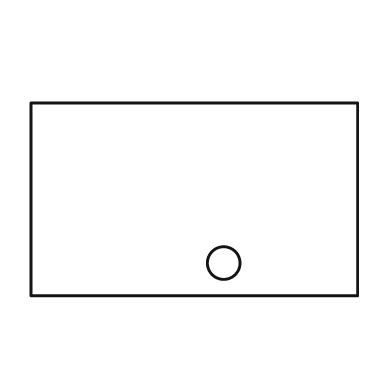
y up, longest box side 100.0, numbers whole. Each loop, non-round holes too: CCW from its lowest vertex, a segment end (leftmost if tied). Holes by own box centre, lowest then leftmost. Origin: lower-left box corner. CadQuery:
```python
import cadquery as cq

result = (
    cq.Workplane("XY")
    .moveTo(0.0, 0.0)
    .lineTo(100.0, 0.0)
    .lineTo(100.0, 59.0)
    .lineTo(0.0, 59.0)
    .close()
    .moveTo(59.0, 10.0)
    .circle(5.0)
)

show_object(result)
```